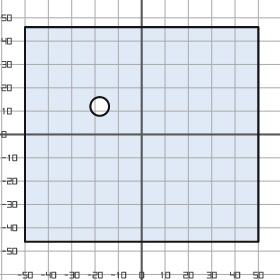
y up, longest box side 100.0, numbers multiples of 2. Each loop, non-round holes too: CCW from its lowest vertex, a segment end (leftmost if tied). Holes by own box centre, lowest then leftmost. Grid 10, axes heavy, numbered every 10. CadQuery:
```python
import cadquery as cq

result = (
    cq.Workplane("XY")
    .moveTo(-50.0, -46.0)
    .lineTo(50.0, -46.0)
    .lineTo(50.0, 46.0)
    .lineTo(-50.0, 46.0)
    .close()
    .moveTo(-18.0, 12.0)
    .circle(4.0)
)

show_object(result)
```